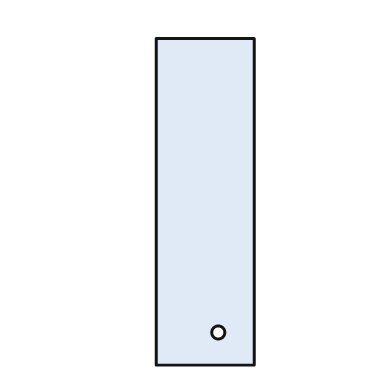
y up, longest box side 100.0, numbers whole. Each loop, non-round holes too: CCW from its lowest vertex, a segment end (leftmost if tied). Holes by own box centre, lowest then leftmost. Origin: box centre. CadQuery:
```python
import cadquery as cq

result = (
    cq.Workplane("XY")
    .moveTo(-15.0, -50.0)
    .lineTo(15.0, -50.0)
    .lineTo(15.0, 50.0)
    .lineTo(-15.0, 50.0)
    .close()
    .moveTo(4.0, -40.0)
    .circle(2.0)
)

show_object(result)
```